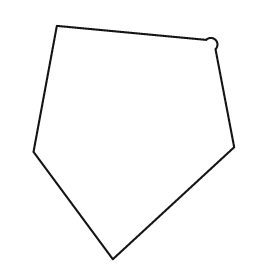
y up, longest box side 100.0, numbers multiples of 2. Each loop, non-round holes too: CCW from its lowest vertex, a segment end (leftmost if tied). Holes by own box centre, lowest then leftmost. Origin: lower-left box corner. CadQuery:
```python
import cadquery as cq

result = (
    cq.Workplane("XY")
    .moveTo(34.0, 0.0)
    .lineTo(86.0, 48.0)
    .lineTo(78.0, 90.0)
    .threePointArc((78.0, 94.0), (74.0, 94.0))
    .lineTo(10.0, 100.0)
    .lineTo(0.0, 46.0)
    .close()
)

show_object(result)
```